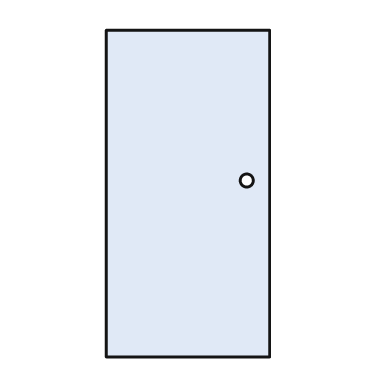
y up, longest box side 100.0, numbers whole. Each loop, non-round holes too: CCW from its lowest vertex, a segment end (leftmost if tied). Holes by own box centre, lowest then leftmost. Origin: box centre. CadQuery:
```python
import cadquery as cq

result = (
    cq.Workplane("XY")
    .moveTo(-25.0, -50.0)
    .lineTo(25.0, -50.0)
    .lineTo(25.0, 50.0)
    .lineTo(-25.0, 50.0)
    .close()
    .moveTo(18.0, 4.0)
    .circle(2.0)
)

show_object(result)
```